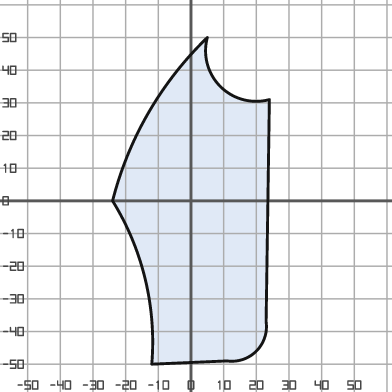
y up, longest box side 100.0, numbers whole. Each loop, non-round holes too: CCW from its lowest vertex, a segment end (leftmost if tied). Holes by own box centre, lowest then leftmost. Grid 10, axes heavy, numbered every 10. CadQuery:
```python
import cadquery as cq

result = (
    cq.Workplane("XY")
    .moveTo(-12.0, -50.0)
    .lineTo(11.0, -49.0)
    .threePointArc((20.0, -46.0), (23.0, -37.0))
    .lineTo(24.0, 31.0)
    .threePointArc((9.0, 35.0), (5.0, 50.0))
    .threePointArc((-13.0, 27.0), (-24.0, 0.0))
    .threePointArc((-14.0, -24.0), (-12.0, -50.0))
    .close()
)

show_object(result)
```